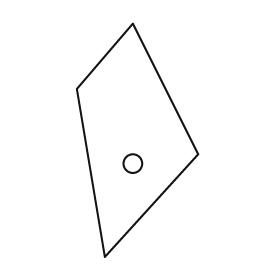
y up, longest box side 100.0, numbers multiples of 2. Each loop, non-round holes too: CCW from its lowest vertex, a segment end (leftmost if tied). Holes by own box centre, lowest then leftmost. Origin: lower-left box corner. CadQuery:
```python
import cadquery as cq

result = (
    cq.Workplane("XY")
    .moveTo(12.0, 0.0)
    .lineTo(52.0, 44.0)
    .lineTo(24.0, 100.0)
    .lineTo(0.0, 72.0)
    .close()
    .moveTo(24.0, 40.0)
    .circle(4.0)
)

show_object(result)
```